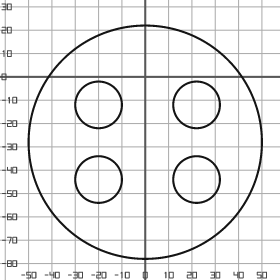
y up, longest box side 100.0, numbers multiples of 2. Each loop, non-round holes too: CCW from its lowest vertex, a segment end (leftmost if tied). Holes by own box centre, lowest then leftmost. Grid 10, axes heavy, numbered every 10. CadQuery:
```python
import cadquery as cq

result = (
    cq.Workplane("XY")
    .moveTo(0.0, -28.0)
    .circle(50.0)
    .moveTo(-20.0, -44.0)
    .circle(10.0)
    .moveTo(22.0, -44.0)
    .circle(10.0)
    .moveTo(-20.0, -12.0)
    .circle(10.0)
    .moveTo(22.0, -12.0)
    .circle(10.0)
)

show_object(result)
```